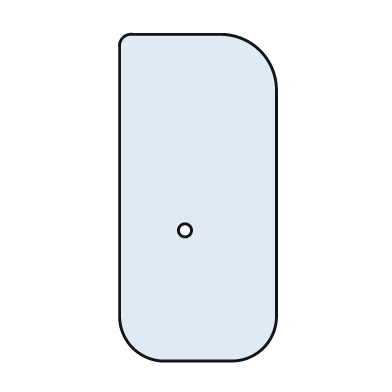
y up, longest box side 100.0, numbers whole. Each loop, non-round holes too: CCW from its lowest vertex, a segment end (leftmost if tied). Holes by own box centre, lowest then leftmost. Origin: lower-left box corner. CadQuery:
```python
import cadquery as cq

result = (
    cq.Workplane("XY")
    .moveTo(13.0, 0.0)
    .lineTo(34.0, 0.0)
    .threePointArc((44.0, 4.0), (48.0, 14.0))
    .lineTo(48.0, 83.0)
    .threePointArc((43.0, 95.0), (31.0, 100.0))
    .lineTo(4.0, 100.0)
    .threePointArc((1.0, 99.0), (0.0, 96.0))
    .lineTo(0.0, 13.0)
    .threePointArc((4.0, 4.0), (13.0, 0.0))
    .close()
    .moveTo(20.0, 40.0)
    .circle(2.0)
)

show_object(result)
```